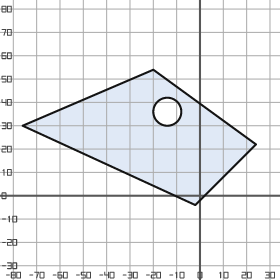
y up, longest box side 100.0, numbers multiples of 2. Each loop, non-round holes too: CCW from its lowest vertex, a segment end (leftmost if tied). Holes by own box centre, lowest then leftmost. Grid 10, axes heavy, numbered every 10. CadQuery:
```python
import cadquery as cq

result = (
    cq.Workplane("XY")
    .moveTo(-2.0, -4.0)
    .lineTo(24.0, 22.0)
    .lineTo(-20.0, 54.0)
    .lineTo(-76.0, 30.0)
    .close()
    .moveTo(-14.0, 36.0)
    .circle(6.0)
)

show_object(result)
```